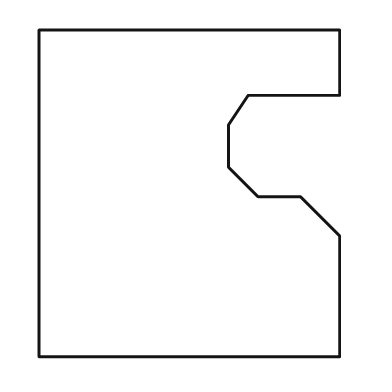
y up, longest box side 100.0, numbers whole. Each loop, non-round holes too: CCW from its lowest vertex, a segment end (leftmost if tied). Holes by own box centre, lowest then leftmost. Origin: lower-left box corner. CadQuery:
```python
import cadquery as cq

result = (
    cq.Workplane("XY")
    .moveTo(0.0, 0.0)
    .lineTo(92.0, 0.0)
    .lineTo(92.0, 37.0)
    .lineTo(80.0, 49.0)
    .lineTo(67.0, 49.0)
    .lineTo(58.0, 58.0)
    .lineTo(58.0, 71.0)
    .lineTo(64.0, 80.0)
    .lineTo(92.0, 80.0)
    .lineTo(92.0, 100.0)
    .lineTo(0.0, 100.0)
    .close()
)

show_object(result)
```